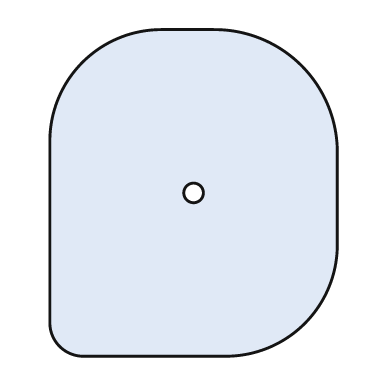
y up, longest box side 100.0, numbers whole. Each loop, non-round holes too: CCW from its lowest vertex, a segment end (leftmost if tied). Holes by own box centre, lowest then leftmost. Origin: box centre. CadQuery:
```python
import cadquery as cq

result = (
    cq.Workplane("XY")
    .moveTo(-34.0, -50.0)
    .lineTo(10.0, -50.0)
    .threePointArc((34.0, -40.0), (44.0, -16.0))
    .lineTo(44.0, 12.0)
    .threePointArc((33.0, 39.0), (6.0, 50.0))
    .lineTo(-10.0, 50.0)
    .threePointArc((-34.0, 40.0), (-44.0, 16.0))
    .lineTo(-44.0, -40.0)
    .threePointArc((-41.0, -47.0), (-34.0, -50.0))
    .close()
    .moveTo(0.0, 0.0)
    .circle(3.0)
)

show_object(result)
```